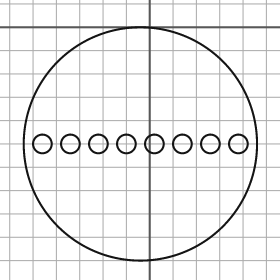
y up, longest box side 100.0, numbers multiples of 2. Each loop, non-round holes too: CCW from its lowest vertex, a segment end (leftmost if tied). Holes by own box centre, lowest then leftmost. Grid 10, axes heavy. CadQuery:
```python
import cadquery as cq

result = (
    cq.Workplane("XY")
    .moveTo(-4.0, -50.0)
    .circle(50.0)
    .moveTo(-46.0, -50.0)
    .circle(4.0)
    .moveTo(-34.0, -50.0)
    .circle(4.0)
    .moveTo(-22.0, -50.0)
    .circle(4.0)
    .moveTo(-10.0, -50.0)
    .circle(4.0)
    .moveTo(2.0, -50.0)
    .circle(4.0)
    .moveTo(14.0, -50.0)
    .circle(4.0)
    .moveTo(26.0, -50.0)
    .circle(4.0)
    .moveTo(38.0, -50.0)
    .circle(4.0)
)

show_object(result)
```